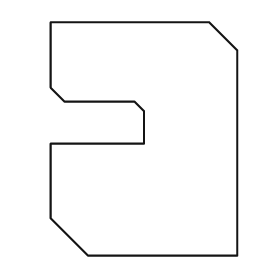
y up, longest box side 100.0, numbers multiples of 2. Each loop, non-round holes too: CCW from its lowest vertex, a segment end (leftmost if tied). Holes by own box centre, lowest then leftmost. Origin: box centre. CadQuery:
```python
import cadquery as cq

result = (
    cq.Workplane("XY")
    .moveTo(-24.0, -50.0)
    .lineTo(40.0, -50.0)
    .lineTo(40.0, 38.0)
    .lineTo(28.0, 50.0)
    .lineTo(-40.0, 50.0)
    .lineTo(-40.0, 22.0)
    .lineTo(-34.0, 16.0)
    .lineTo(-4.0, 16.0)
    .lineTo(0.0, 12.0)
    .lineTo(0.0, -2.0)
    .lineTo(-40.0, -2.0)
    .lineTo(-40.0, -34.0)
    .close()
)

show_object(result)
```